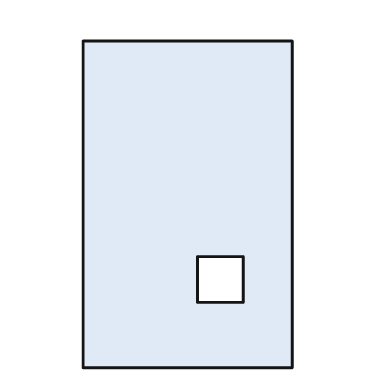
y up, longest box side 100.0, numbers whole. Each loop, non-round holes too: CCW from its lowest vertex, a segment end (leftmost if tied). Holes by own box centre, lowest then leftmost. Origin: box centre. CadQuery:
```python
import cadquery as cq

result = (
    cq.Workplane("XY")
    .moveTo(-32.0, -50.0)
    .lineTo(32.0, -50.0)
    .lineTo(32.0, 50.0)
    .lineTo(-32.0, 50.0)
    .close()
    .moveTo(3.0, -30.0)
    .lineTo(17.0, -30.0)
    .lineTo(17.0, -16.0)
    .lineTo(3.0, -16.0)
    .close()
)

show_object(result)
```